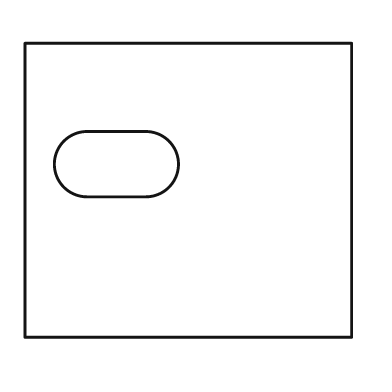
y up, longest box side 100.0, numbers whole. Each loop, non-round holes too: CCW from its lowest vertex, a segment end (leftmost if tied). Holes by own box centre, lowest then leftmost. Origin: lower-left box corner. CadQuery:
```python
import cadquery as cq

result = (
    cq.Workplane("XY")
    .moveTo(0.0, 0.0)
    .lineTo(100.0, 0.0)
    .lineTo(100.0, 90.0)
    .lineTo(0.0, 90.0)
    .close()
    .moveTo(19.0, 43.0)
    .lineTo(37.0, 43.0)
    .threePointArc((47.0, 53.0), (37.0, 63.0))
    .lineTo(19.0, 63.0)
    .threePointArc((9.0, 53.0), (19.0, 43.0))
    .close()
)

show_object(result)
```